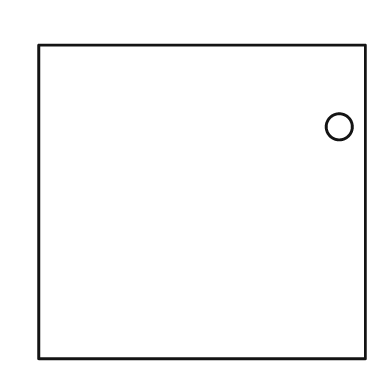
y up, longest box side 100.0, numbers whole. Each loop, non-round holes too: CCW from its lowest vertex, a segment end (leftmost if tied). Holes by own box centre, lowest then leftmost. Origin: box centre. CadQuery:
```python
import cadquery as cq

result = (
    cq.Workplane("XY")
    .moveTo(-50.0, -48.0)
    .lineTo(50.0, -48.0)
    .lineTo(50.0, 48.0)
    .lineTo(-50.0, 48.0)
    .close()
    .moveTo(42.0, 23.0)
    .circle(4.0)
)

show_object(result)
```